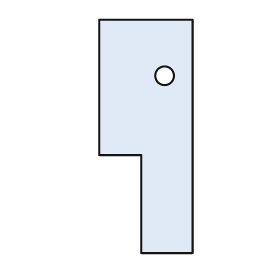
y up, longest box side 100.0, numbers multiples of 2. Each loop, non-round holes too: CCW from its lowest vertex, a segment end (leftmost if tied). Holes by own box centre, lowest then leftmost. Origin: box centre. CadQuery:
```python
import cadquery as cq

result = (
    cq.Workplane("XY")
    .moveTo(-2.0, -50.0)
    .lineTo(20.0, -50.0)
    .lineTo(20.0, 50.0)
    .lineTo(-20.0, 50.0)
    .lineTo(-20.0, -8.0)
    .lineTo(-2.0, -8.0)
    .close()
    .moveTo(8.0, 26.0)
    .circle(4.0)
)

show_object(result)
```